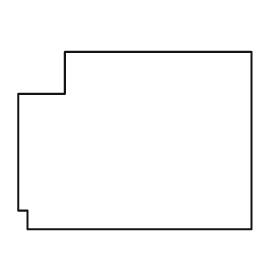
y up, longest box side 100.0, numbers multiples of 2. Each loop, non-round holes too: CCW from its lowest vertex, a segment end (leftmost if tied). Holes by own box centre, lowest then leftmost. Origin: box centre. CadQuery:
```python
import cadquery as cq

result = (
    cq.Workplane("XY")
    .moveTo(-46.0, -38.0)
    .lineTo(50.0, -38.0)
    .lineTo(50.0, 38.0)
    .lineTo(-30.0, 38.0)
    .lineTo(-30.0, 20.0)
    .lineTo(-50.0, 20.0)
    .lineTo(-50.0, -30.0)
    .lineTo(-46.0, -30.0)
    .close()
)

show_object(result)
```